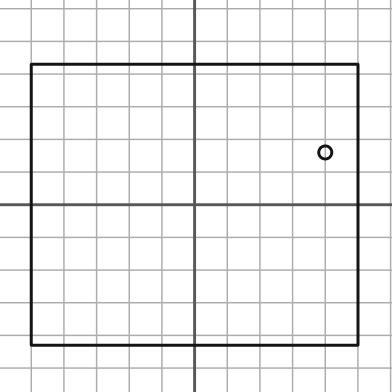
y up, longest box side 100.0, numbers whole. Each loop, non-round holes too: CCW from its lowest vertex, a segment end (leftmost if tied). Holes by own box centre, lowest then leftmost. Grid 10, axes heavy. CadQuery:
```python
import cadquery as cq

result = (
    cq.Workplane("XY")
    .moveTo(-50.0, -43.0)
    .lineTo(50.0, -43.0)
    .lineTo(50.0, 43.0)
    .lineTo(-50.0, 43.0)
    .close()
    .moveTo(40.0, 16.0)
    .circle(2.0)
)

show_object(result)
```